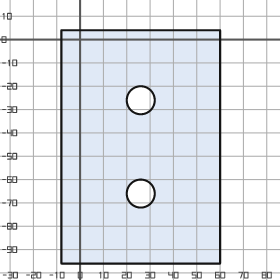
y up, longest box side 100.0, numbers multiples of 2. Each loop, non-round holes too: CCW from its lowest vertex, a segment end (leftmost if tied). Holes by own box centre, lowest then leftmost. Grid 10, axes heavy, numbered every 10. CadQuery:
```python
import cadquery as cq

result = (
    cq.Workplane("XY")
    .moveTo(-8.0, -96.0)
    .lineTo(60.0, -96.0)
    .lineTo(60.0, 4.0)
    .lineTo(-8.0, 4.0)
    .close()
    .moveTo(26.0, -66.0)
    .circle(6.0)
    .moveTo(26.0, -26.0)
    .circle(6.0)
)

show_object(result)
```